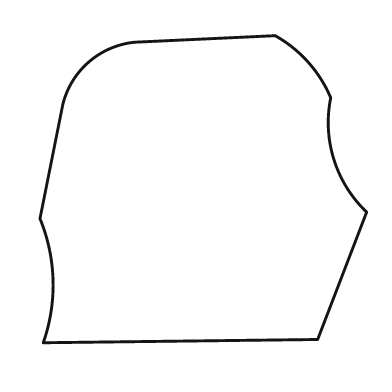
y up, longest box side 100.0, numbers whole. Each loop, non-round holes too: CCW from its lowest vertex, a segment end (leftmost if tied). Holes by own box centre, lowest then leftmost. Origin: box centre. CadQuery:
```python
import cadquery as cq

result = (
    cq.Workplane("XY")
    .moveTo(-49.0, -47.0)
    .lineTo(35.0, -46.0)
    .lineTo(50.0, -7.0)
    .threePointArc((40.0, 9.0), (39.0, 28.0))
    .threePointArc((32.0, 39.0), (22.0, 47.0))
    .lineTo(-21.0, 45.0)
    .threePointArc((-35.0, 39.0), (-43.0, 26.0))
    .lineTo(-50.0, -9.0)
    .threePointArc((-46.0, -28.0), (-49.0, -47.0))
    .close()
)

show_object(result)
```